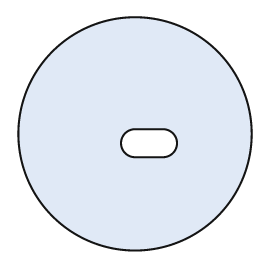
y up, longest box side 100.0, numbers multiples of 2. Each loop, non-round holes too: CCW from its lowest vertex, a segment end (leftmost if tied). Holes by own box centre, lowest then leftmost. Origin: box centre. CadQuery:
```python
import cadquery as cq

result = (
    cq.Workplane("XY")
    .moveTo(0.0, 0.0)
    .circle(50.0)
    .moveTo(0.0, -10.0)
    .lineTo(12.0, -10.0)
    .threePointArc((18.0, -4.0), (12.0, 2.0))
    .lineTo(0.0, 2.0)
    .threePointArc((-6.0, -4.0), (0.0, -10.0))
    .close()
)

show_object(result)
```